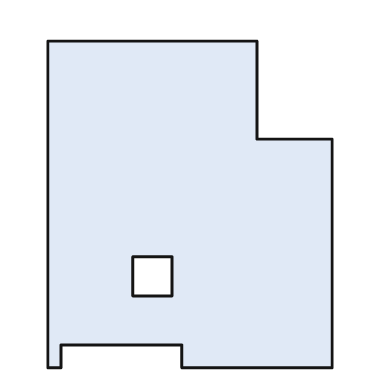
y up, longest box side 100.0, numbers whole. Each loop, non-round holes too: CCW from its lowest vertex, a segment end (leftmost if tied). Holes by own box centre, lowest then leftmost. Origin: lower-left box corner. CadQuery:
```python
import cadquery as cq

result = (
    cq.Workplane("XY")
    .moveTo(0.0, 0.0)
    .lineTo(4.0, 0.0)
    .lineTo(4.0, 7.0)
    .lineTo(41.0, 7.0)
    .lineTo(41.0, 0.0)
    .lineTo(87.0, 0.0)
    .lineTo(87.0, 70.0)
    .lineTo(64.0, 70.0)
    .lineTo(64.0, 100.0)
    .lineTo(0.0, 100.0)
    .close()
    .moveTo(26.0, 22.0)
    .lineTo(38.0, 22.0)
    .lineTo(38.0, 34.0)
    .lineTo(26.0, 34.0)
    .close()
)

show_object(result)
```